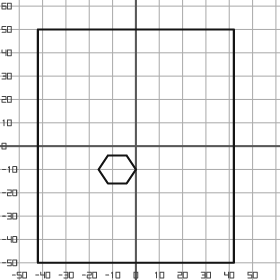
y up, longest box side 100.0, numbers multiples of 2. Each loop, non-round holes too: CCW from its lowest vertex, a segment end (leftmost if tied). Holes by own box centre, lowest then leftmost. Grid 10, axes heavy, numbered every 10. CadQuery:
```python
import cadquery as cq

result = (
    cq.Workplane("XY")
    .moveTo(-42.0, -50.0)
    .lineTo(42.0, -50.0)
    .lineTo(42.0, 50.0)
    .lineTo(-42.0, 50.0)
    .close()
    .moveTo(-12.0, -16.0)
    .lineTo(-4.0, -16.0)
    .lineTo(0.0, -10.0)
    .lineTo(-4.0, -4.0)
    .lineTo(-12.0, -4.0)
    .lineTo(-16.0, -10.0)
    .close()
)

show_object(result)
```